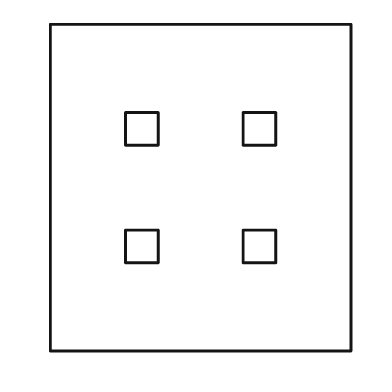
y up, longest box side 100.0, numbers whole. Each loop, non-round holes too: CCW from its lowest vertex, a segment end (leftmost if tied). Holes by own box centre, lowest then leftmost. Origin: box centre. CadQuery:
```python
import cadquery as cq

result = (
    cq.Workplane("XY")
    .moveTo(-46.0, -50.0)
    .lineTo(46.0, -50.0)
    .lineTo(46.0, 50.0)
    .lineTo(-46.0, 50.0)
    .close()
    .moveTo(-23.0, -23.0)
    .lineTo(-13.0, -23.0)
    .lineTo(-13.0, -13.0)
    .lineTo(-23.0, -13.0)
    .close()
    .moveTo(13.0, -23.0)
    .lineTo(23.0, -23.0)
    .lineTo(23.0, -13.0)
    .lineTo(13.0, -13.0)
    .close()
    .moveTo(-23.0, 13.0)
    .lineTo(-13.0, 13.0)
    .lineTo(-13.0, 23.0)
    .lineTo(-23.0, 23.0)
    .close()
    .moveTo(13.0, 13.0)
    .lineTo(23.0, 13.0)
    .lineTo(23.0, 23.0)
    .lineTo(13.0, 23.0)
    .close()
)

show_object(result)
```